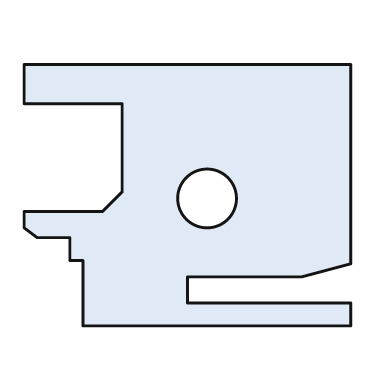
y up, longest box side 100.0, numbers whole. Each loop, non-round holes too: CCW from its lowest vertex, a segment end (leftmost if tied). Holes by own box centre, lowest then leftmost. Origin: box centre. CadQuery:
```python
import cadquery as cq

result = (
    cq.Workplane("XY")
    .moveTo(-32.0, -40.0)
    .lineTo(50.0, -40.0)
    .lineTo(50.0, -33.0)
    .lineTo(0.0, -33.0)
    .lineTo(0.0, -25.0)
    .lineTo(35.0, -25.0)
    .lineTo(50.0, -21.0)
    .lineTo(50.0, 40.0)
    .lineTo(-50.0, 40.0)
    .lineTo(-50.0, 28.0)
    .lineTo(-20.0, 28.0)
    .lineTo(-20.0, 1.0)
    .lineTo(-26.0, -5.0)
    .lineTo(-50.0, -5.0)
    .lineTo(-50.0, -10.0)
    .lineTo(-46.0, -13.0)
    .lineTo(-36.0, -13.0)
    .lineTo(-36.0, -20.0)
    .lineTo(-32.0, -20.0)
    .close()
    .moveTo(6.0, -1.0)
    .circle(9.0)
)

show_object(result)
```